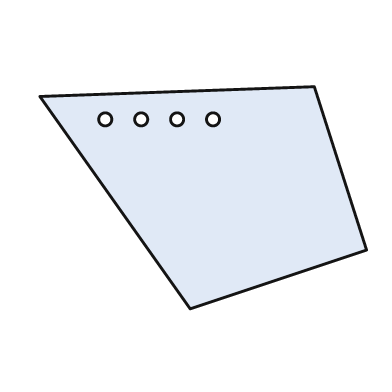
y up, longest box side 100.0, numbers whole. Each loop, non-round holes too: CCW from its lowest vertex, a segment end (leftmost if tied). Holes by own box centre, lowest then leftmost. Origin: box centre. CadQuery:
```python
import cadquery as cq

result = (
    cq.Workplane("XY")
    .moveTo(-4.0, -34.0)
    .lineTo(50.0, -16.0)
    .lineTo(34.0, 34.0)
    .lineTo(-50.0, 31.0)
    .close()
    .moveTo(-30.0, 24.0)
    .circle(2.0)
    .moveTo(-19.0, 24.0)
    .circle(2.0)
    .moveTo(-8.0, 24.0)
    .circle(2.0)
    .moveTo(3.0, 24.0)
    .circle(2.0)
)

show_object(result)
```